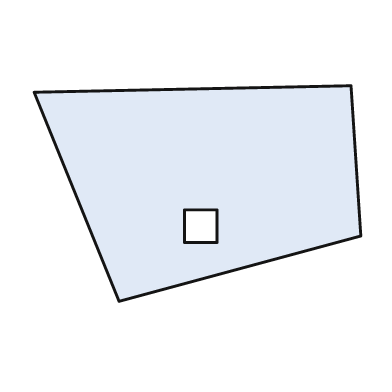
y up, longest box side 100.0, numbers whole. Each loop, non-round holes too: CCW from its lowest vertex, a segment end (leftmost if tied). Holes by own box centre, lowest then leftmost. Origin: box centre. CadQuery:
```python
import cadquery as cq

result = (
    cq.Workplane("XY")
    .moveTo(-24.0, -33.0)
    .lineTo(50.0, -13.0)
    .lineTo(47.0, 33.0)
    .lineTo(-50.0, 31.0)
    .close()
    .moveTo(-4.0, -15.0)
    .lineTo(6.0, -15.0)
    .lineTo(6.0, -5.0)
    .lineTo(-4.0, -5.0)
    .close()
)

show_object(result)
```